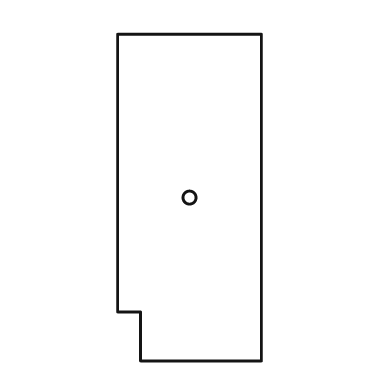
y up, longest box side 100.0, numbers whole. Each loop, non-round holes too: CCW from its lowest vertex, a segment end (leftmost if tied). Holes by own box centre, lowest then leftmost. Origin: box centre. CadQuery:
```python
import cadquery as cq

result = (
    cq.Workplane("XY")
    .moveTo(-15.0, -50.0)
    .lineTo(22.0, -50.0)
    .lineTo(22.0, 50.0)
    .lineTo(-22.0, 50.0)
    .lineTo(-22.0, -35.0)
    .lineTo(-15.0, -35.0)
    .close()
    .moveTo(0.0, 0.0)
    .circle(2.0)
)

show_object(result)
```